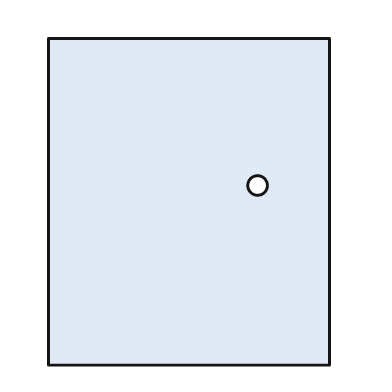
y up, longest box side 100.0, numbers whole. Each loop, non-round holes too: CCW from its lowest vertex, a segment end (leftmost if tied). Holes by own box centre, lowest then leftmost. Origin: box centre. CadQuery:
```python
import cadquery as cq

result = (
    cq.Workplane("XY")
    .moveTo(-43.0, -50.0)
    .lineTo(43.0, -50.0)
    .lineTo(43.0, 50.0)
    .lineTo(-43.0, 50.0)
    .close()
    .moveTo(21.0, 5.0)
    .circle(3.0)
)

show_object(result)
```